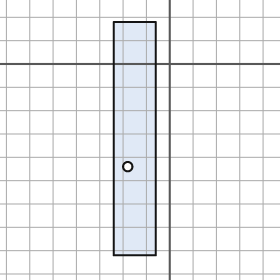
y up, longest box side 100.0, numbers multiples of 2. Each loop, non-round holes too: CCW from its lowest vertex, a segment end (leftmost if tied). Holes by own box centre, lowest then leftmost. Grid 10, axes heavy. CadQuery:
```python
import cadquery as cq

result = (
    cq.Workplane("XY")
    .moveTo(-24.0, -82.0)
    .lineTo(-6.0, -82.0)
    .lineTo(-6.0, 18.0)
    .lineTo(-24.0, 18.0)
    .close()
    .moveTo(-18.0, -44.0)
    .circle(2.0)
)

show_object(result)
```